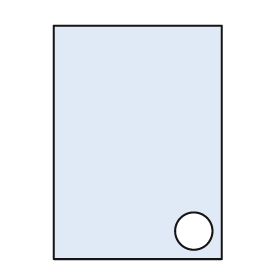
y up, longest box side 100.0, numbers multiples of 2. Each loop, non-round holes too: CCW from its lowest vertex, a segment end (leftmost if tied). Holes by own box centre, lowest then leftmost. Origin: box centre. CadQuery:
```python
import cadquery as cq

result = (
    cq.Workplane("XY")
    .moveTo(-36.0, -50.0)
    .lineTo(36.0, -50.0)
    .lineTo(36.0, 50.0)
    .lineTo(-36.0, 50.0)
    .close()
    .moveTo(24.0, -38.0)
    .circle(8.0)
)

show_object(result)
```